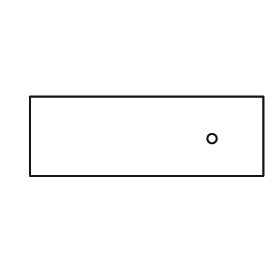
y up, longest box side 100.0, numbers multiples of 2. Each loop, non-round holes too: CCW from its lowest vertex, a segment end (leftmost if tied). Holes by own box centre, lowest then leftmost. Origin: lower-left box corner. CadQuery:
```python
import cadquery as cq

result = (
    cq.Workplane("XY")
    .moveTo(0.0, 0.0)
    .lineTo(100.0, 0.0)
    .lineTo(100.0, 34.0)
    .lineTo(0.0, 34.0)
    .close()
    .moveTo(78.0, 16.0)
    .circle(2.0)
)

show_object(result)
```